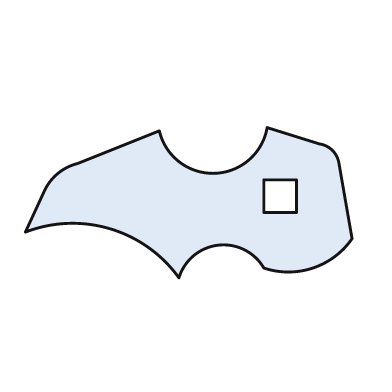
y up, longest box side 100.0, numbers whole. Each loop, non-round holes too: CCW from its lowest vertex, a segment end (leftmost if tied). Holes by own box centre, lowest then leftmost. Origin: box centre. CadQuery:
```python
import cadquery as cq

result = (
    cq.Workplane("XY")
    .moveTo(-3.0, -23.0)
    .threePointArc((9.0, -13.0), (23.0, -20.0))
    .threePointArc((38.0, -20.0), (50.0, -11.0))
    .lineTo(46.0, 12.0)
    .threePointArc((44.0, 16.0), (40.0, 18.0))
    .lineTo(24.0, 23.0)
    .threePointArc((8.0, 9.0), (-9.0, 22.0))
    .lineTo(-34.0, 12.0)
    .threePointArc((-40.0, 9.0), (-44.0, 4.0))
    .lineTo(-50.0, -9.0)
    .threePointArc((-24.0, -8.0), (-3.0, -23.0))
    .close()
    .moveTo(23.0, -3.0)
    .lineTo(33.0, -3.0)
    .lineTo(33.0, 7.0)
    .lineTo(23.0, 7.0)
    .close()
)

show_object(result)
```